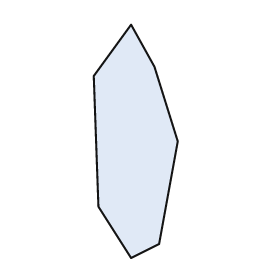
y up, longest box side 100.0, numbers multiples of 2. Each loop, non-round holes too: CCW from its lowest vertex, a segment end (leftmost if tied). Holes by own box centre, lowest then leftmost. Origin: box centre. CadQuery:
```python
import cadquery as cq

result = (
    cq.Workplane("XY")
    .moveTo(-2.0, -50.0)
    .lineTo(10.0, -44.0)
    .lineTo(18.0, 0.0)
    .lineTo(8.0, 32.0)
    .lineTo(-2.0, 50.0)
    .lineTo(-18.0, 28.0)
    .lineTo(-16.0, -28.0)
    .close()
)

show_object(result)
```